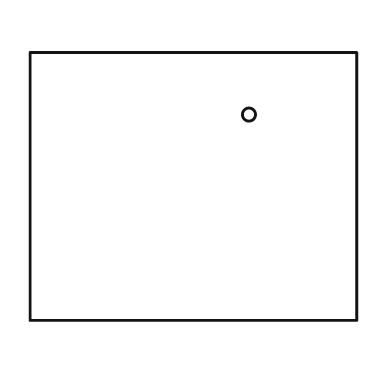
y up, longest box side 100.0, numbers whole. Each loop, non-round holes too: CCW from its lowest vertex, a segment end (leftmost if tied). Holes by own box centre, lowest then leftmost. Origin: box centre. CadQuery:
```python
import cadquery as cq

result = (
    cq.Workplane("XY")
    .moveTo(-50.0, -41.0)
    .lineTo(50.0, -41.0)
    .lineTo(50.0, 41.0)
    .lineTo(-50.0, 41.0)
    .close()
    .moveTo(17.0, 22.0)
    .circle(2.0)
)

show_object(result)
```